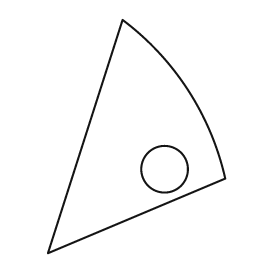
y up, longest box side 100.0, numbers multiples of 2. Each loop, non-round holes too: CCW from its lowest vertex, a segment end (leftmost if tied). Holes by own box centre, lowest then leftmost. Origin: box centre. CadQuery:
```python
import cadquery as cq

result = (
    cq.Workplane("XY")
    .moveTo(-38.0, -50.0)
    .lineTo(38.0, -18.0)
    .threePointArc((22.0, 20.0), (-6.0, 50.0))
    .close()
    .moveTo(12.0, -14.0)
    .circle(10.0)
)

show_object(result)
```